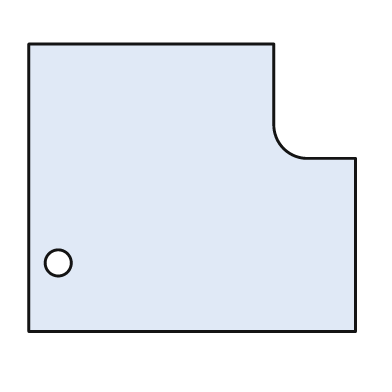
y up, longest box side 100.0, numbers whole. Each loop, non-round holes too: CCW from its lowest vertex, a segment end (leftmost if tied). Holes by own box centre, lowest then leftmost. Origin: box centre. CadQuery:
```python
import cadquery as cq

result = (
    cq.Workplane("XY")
    .moveTo(-50.0, -44.0)
    .lineTo(50.0, -44.0)
    .lineTo(50.0, 9.0)
    .lineTo(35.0, 9.0)
    .threePointArc((28.0, 12.0), (25.0, 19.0))
    .lineTo(25.0, 44.0)
    .lineTo(-50.0, 44.0)
    .close()
    .moveTo(-41.0, -23.0)
    .circle(4.0)
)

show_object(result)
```